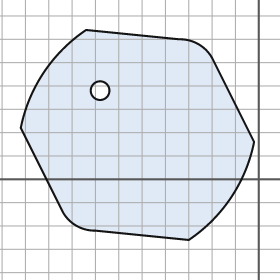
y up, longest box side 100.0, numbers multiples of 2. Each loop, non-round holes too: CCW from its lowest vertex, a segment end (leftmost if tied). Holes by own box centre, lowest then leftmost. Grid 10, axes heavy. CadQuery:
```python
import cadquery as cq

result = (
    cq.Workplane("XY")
    .moveTo(-30.0, -26.0)
    .threePointArc((-12.0, -8.0), (-2.0, 16.0))
    .lineTo(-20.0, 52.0)
    .threePointArc((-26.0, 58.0), (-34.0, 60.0))
    .lineTo(-74.0, 64.0)
    .threePointArc((-92.0, 46.0), (-102.0, 22.0))
    .lineTo(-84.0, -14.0)
    .threePointArc((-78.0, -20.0), (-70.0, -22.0))
    .close()
    .moveTo(-68.0, 38.0)
    .circle(4.0)
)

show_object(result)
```